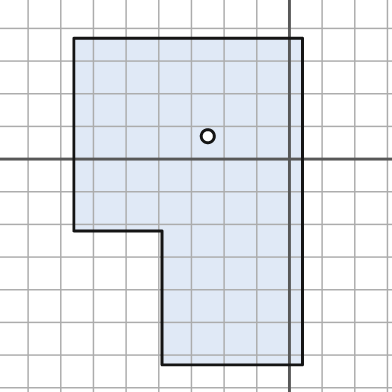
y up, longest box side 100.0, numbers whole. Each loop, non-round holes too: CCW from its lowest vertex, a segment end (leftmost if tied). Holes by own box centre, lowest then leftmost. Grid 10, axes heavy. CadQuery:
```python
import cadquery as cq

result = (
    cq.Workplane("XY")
    .moveTo(-39.0, -63.0)
    .lineTo(4.0, -63.0)
    .lineTo(4.0, 37.0)
    .lineTo(-66.0, 37.0)
    .lineTo(-66.0, -22.0)
    .lineTo(-39.0, -22.0)
    .close()
    .moveTo(-25.0, 7.0)
    .circle(2.0)
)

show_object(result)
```